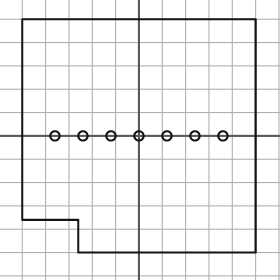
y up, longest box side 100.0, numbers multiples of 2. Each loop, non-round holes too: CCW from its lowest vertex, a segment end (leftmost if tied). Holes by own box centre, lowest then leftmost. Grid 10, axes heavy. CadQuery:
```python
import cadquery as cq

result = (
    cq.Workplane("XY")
    .moveTo(-26.0, -50.0)
    .lineTo(50.0, -50.0)
    .lineTo(50.0, 50.0)
    .lineTo(-50.0, 50.0)
    .lineTo(-50.0, -36.0)
    .lineTo(-26.0, -36.0)
    .close()
    .moveTo(-36.0, 0.0)
    .circle(2.0)
    .moveTo(-24.0, 0.0)
    .circle(2.0)
    .moveTo(-12.0, 0.0)
    .circle(2.0)
    .moveTo(0.0, 0.0)
    .circle(2.0)
    .moveTo(12.0, 0.0)
    .circle(2.0)
    .moveTo(24.0, 0.0)
    .circle(2.0)
    .moveTo(36.0, 0.0)
    .circle(2.0)
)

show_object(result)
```